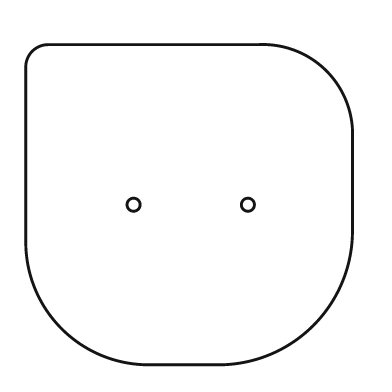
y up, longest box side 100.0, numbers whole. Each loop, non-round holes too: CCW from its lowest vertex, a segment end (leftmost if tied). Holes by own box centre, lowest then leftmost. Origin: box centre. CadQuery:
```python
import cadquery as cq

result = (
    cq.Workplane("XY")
    .moveTo(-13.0, -49.0)
    .lineTo(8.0, -49.0)
    .threePointArc((38.0, -37.0), (50.0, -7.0))
    .lineTo(50.0, 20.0)
    .threePointArc((42.0, 41.0), (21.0, 49.0))
    .lineTo(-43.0, 49.0)
    .threePointArc((-48.0, 47.0), (-50.0, 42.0))
    .lineTo(-50.0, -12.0)
    .threePointArc((-39.0, -38.0), (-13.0, -49.0))
    .close()
    .moveTo(-17.0, 0.0)
    .circle(2.0)
    .moveTo(18.0, 0.0)
    .circle(2.0)
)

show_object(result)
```